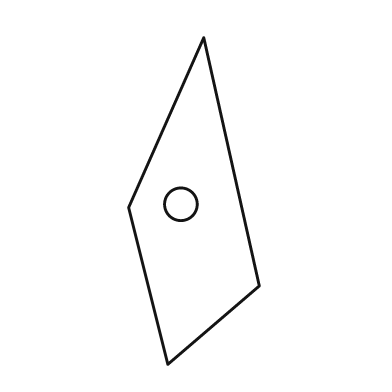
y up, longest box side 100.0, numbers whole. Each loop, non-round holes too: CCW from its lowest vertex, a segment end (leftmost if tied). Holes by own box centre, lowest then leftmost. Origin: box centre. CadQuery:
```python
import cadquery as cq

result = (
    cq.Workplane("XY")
    .moveTo(-8.0, -50.0)
    .lineTo(20.0, -26.0)
    .lineTo(3.0, 50.0)
    .lineTo(-20.0, -2.0)
    .close()
    .moveTo(-4.0, -1.0)
    .circle(5.0)
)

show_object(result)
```